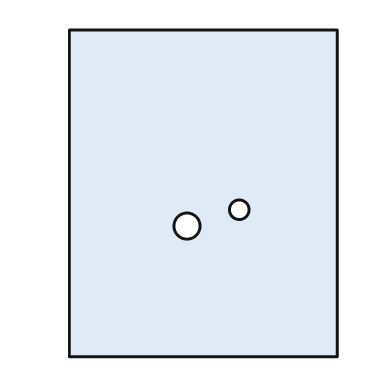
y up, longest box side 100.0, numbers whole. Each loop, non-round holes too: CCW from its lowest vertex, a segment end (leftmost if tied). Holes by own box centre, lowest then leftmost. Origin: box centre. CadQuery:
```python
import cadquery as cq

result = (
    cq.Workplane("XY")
    .moveTo(-41.0, -50.0)
    .lineTo(41.0, -50.0)
    .lineTo(41.0, 50.0)
    .lineTo(-41.0, 50.0)
    .close()
    .moveTo(-5.0, -10.0)
    .circle(4.0)
    .moveTo(11.0, -5.0)
    .circle(3.0)
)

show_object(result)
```